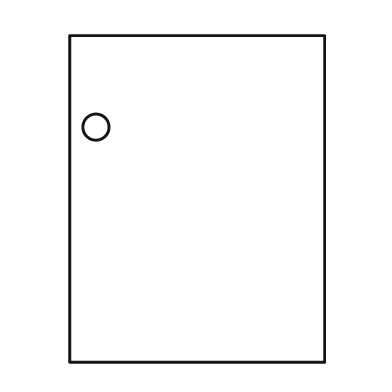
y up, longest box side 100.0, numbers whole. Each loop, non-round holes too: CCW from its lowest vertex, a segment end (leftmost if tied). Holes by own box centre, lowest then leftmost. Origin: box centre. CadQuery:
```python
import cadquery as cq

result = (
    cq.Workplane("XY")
    .moveTo(-39.0, -50.0)
    .lineTo(39.0, -50.0)
    .lineTo(39.0, 50.0)
    .lineTo(-39.0, 50.0)
    .close()
    .moveTo(-31.0, 22.0)
    .circle(4.0)
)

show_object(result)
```